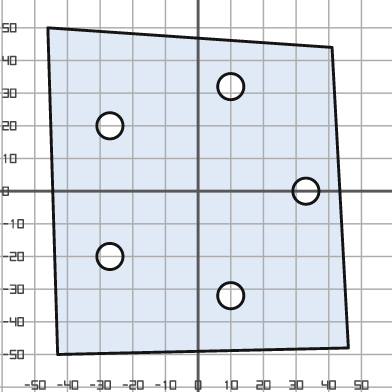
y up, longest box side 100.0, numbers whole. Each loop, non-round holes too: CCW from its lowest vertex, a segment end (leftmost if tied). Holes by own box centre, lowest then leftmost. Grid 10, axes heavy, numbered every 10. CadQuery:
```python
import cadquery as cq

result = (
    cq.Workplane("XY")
    .moveTo(-43.0, -50.0)
    .lineTo(46.0, -48.0)
    .lineTo(41.0, 44.0)
    .lineTo(-46.0, 50.0)
    .close()
    .moveTo(10.0, -32.0)
    .circle(4.0)
    .moveTo(-27.0, -20.0)
    .circle(4.0)
    .moveTo(33.0, 0.0)
    .circle(4.0)
    .moveTo(-27.0, 20.0)
    .circle(4.0)
    .moveTo(10.0, 32.0)
    .circle(4.0)
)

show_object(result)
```